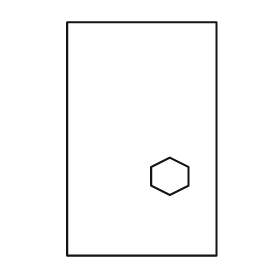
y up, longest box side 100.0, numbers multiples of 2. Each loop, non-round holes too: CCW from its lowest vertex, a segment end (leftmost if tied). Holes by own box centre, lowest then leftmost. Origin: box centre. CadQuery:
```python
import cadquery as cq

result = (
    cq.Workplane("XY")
    .moveTo(-32.0, -50.0)
    .lineTo(32.0, -50.0)
    .lineTo(32.0, 50.0)
    .lineTo(-32.0, 50.0)
    .close()
    .moveTo(12.0, -24.0)
    .lineTo(20.0, -20.0)
    .lineTo(20.0, -12.0)
    .lineTo(12.0, -8.0)
    .lineTo(4.0, -12.0)
    .lineTo(4.0, -20.0)
    .close()
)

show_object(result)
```